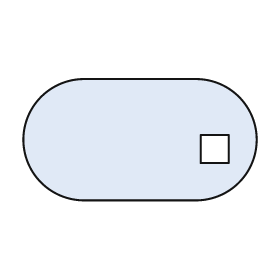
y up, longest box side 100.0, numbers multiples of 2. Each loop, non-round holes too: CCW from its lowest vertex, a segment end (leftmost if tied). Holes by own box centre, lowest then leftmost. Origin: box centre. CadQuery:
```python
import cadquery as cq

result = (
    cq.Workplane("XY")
    .moveTo(-24.0, -26.0)
    .lineTo(24.0, -26.0)
    .threePointArc((50.0, 0.0), (24.0, 26.0))
    .lineTo(-24.0, 26.0)
    .threePointArc((-50.0, 0.0), (-24.0, -26.0))
    .close()
    .moveTo(26.0, -10.0)
    .lineTo(38.0, -10.0)
    .lineTo(38.0, 2.0)
    .lineTo(26.0, 2.0)
    .close()
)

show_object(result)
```